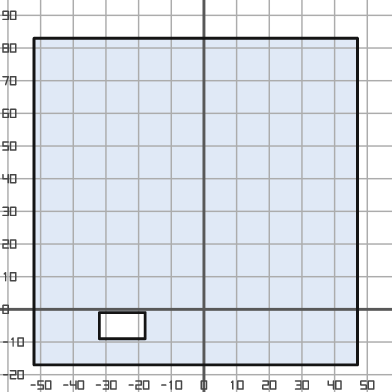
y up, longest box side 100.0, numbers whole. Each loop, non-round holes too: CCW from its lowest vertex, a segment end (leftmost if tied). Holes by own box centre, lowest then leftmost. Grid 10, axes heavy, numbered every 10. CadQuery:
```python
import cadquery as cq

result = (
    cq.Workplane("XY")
    .moveTo(-52.0, -17.0)
    .lineTo(47.0, -17.0)
    .lineTo(47.0, 83.0)
    .lineTo(-52.0, 83.0)
    .close()
    .moveTo(-32.0, -9.0)
    .lineTo(-18.0, -9.0)
    .lineTo(-18.0, -1.0)
    .lineTo(-32.0, -1.0)
    .close()
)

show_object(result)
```